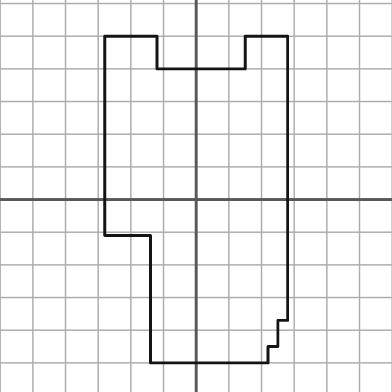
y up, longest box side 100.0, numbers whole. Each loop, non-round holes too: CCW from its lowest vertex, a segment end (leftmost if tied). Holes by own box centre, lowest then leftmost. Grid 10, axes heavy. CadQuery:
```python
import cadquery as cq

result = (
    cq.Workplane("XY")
    .moveTo(-14.0, -50.0)
    .lineTo(22.0, -50.0)
    .lineTo(22.0, -45.0)
    .lineTo(25.0, -45.0)
    .lineTo(25.0, -37.0)
    .lineTo(28.0, -37.0)
    .lineTo(28.0, 50.0)
    .lineTo(15.0, 50.0)
    .lineTo(15.0, 40.0)
    .lineTo(-12.0, 40.0)
    .lineTo(-12.0, 50.0)
    .lineTo(-28.0, 50.0)
    .lineTo(-28.0, -11.0)
    .lineTo(-14.0, -11.0)
    .close()
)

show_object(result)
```